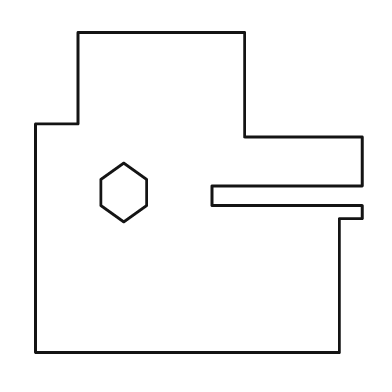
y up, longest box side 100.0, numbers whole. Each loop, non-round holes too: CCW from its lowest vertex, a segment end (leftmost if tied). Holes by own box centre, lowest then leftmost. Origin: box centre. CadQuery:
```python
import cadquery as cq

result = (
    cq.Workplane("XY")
    .moveTo(-50.0, -49.0)
    .lineTo(43.0, -49.0)
    .lineTo(43.0, -8.0)
    .lineTo(50.0, -8.0)
    .lineTo(50.0, -4.0)
    .lineTo(4.0, -4.0)
    .lineTo(4.0, 2.0)
    .lineTo(50.0, 2.0)
    .lineTo(50.0, 17.0)
    .lineTo(14.0, 17.0)
    .lineTo(14.0, 49.0)
    .lineTo(-37.0, 49.0)
    .lineTo(-37.0, 21.0)
    .lineTo(-50.0, 21.0)
    .close()
    .moveTo(-23.0, -9.0)
    .lineTo(-16.0, -4.0)
    .lineTo(-16.0, 4.0)
    .lineTo(-23.0, 9.0)
    .lineTo(-30.0, 4.0)
    .lineTo(-30.0, -4.0)
    .close()
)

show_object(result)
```